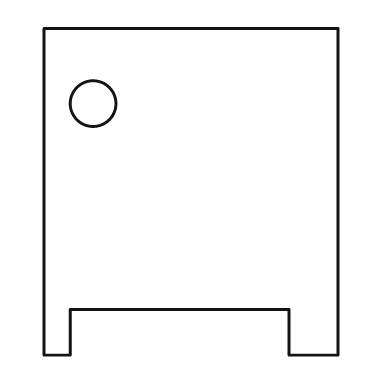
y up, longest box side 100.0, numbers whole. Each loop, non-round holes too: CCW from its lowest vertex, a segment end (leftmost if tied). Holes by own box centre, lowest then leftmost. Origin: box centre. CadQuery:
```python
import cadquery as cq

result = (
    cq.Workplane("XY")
    .moveTo(-45.0, -50.0)
    .lineTo(-37.0, -50.0)
    .lineTo(-37.0, -36.0)
    .lineTo(30.0, -36.0)
    .lineTo(30.0, -50.0)
    .lineTo(45.0, -50.0)
    .lineTo(45.0, 50.0)
    .lineTo(-45.0, 50.0)
    .close()
    .moveTo(-30.0, 27.0)
    .circle(7.0)
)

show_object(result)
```